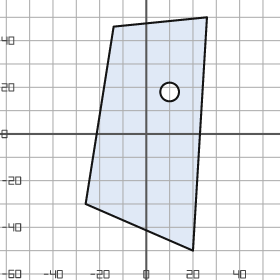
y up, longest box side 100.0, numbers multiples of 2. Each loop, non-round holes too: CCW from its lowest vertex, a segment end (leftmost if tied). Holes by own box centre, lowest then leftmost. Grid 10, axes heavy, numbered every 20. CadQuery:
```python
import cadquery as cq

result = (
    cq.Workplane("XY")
    .moveTo(20.0, -50.0)
    .lineTo(26.0, 50.0)
    .lineTo(-14.0, 46.0)
    .lineTo(-26.0, -30.0)
    .close()
    .moveTo(10.0, 18.0)
    .circle(4.0)
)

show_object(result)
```